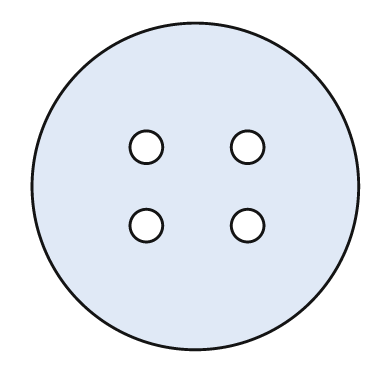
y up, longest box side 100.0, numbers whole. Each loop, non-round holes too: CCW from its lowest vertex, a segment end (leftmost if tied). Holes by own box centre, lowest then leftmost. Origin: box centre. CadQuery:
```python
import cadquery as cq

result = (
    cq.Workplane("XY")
    .moveTo(0.0, 0.0)
    .circle(50.0)
    .moveTo(-15.0, -12.0)
    .circle(5.0)
    .moveTo(16.0, -12.0)
    .circle(5.0)
    .moveTo(-15.0, 12.0)
    .circle(5.0)
    .moveTo(16.0, 12.0)
    .circle(5.0)
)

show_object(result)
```